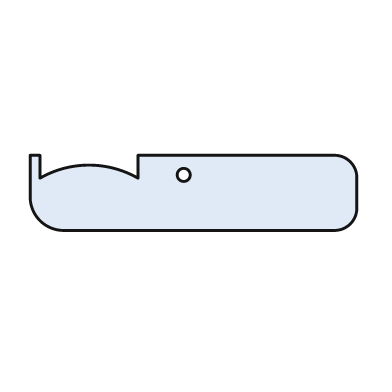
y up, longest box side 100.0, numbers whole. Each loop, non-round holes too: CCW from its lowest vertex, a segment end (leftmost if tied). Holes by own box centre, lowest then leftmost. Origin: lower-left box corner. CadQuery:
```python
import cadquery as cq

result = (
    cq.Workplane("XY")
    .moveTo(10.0, 0.0)
    .lineTo(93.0, 0.0)
    .threePointArc((98.0, 2.0), (100.0, 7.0))
    .lineTo(100.0, 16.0)
    .threePointArc((98.0, 21.0), (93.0, 23.0))
    .lineTo(33.0, 23.0)
    .lineTo(33.0, 16.0)
    .threePointArc((18.0, 20.0), (3.0, 16.0))
    .lineTo(3.0, 23.0)
    .lineTo(0.0, 23.0)
    .lineTo(0.0, 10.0)
    .threePointArc((3.0, 3.0), (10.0, 0.0))
    .close()
    .moveTo(47.0, 17.0)
    .circle(2.0)
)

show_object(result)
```